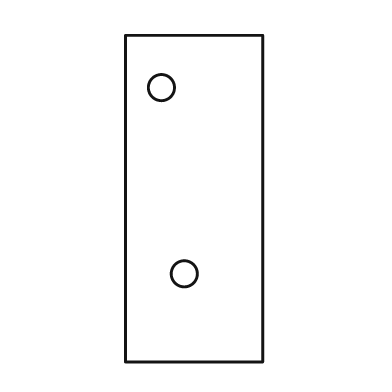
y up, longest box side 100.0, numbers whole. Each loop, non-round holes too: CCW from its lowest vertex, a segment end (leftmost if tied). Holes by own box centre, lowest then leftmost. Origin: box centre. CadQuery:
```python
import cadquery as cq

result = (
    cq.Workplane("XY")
    .moveTo(-21.0, -50.0)
    .lineTo(21.0, -50.0)
    .lineTo(21.0, 50.0)
    .lineTo(-21.0, 50.0)
    .close()
    .moveTo(-3.0, -23.0)
    .circle(4.0)
    .moveTo(-10.0, 34.0)
    .circle(4.0)
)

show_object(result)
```